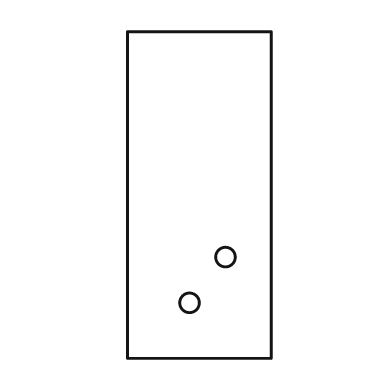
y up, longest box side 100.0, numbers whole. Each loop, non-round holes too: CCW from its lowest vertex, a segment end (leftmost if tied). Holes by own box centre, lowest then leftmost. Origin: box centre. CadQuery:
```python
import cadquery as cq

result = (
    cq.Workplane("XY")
    .moveTo(-22.0, -50.0)
    .lineTo(22.0, -50.0)
    .lineTo(22.0, 50.0)
    .lineTo(-22.0, 50.0)
    .close()
    .moveTo(-3.0, -33.0)
    .circle(3.0)
    .moveTo(8.0, -19.0)
    .circle(3.0)
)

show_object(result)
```